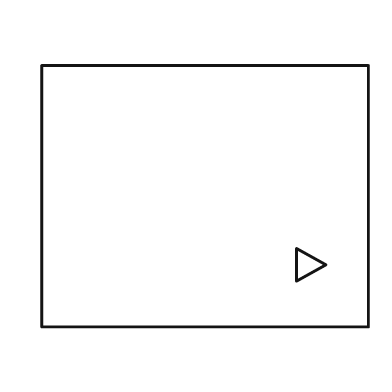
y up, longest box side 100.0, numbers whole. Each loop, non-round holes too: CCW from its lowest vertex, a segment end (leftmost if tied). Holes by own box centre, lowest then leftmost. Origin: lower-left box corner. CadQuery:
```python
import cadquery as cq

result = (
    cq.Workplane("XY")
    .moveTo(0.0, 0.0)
    .lineTo(100.0, 0.0)
    .lineTo(100.0, 80.0)
    .lineTo(0.0, 80.0)
    .close()
    .moveTo(78.0, 14.0)
    .lineTo(87.0, 19.0)
    .lineTo(78.0, 24.0)
    .close()
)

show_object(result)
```